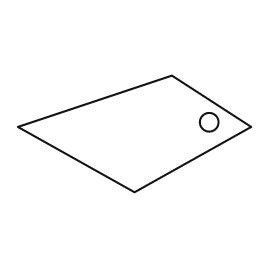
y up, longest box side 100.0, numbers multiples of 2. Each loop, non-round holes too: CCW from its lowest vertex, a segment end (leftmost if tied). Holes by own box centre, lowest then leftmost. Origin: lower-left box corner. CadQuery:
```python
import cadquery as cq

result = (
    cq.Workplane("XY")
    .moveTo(50.0, 0.0)
    .lineTo(100.0, 28.0)
    .lineTo(66.0, 50.0)
    .lineTo(0.0, 28.0)
    .close()
    .moveTo(82.0, 30.0)
    .circle(4.0)
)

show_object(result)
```